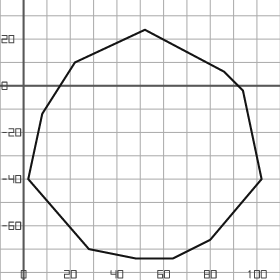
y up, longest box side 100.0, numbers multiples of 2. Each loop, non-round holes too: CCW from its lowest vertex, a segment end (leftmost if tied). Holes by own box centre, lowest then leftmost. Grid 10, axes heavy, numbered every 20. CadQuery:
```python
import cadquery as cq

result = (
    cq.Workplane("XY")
    .moveTo(48.0, -74.0)
    .lineTo(64.0, -74.0)
    .lineTo(80.0, -66.0)
    .lineTo(102.0, -40.0)
    .lineTo(94.0, -2.0)
    .lineTo(86.0, 6.0)
    .lineTo(52.0, 24.0)
    .lineTo(22.0, 10.0)
    .lineTo(8.0, -12.0)
    .lineTo(2.0, -40.0)
    .lineTo(28.0, -70.0)
    .close()
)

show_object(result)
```